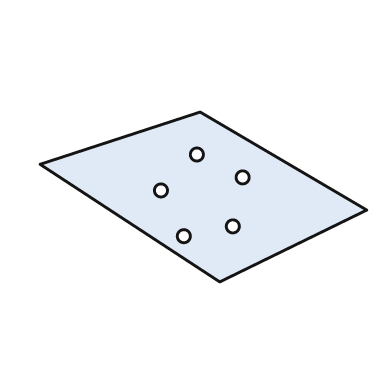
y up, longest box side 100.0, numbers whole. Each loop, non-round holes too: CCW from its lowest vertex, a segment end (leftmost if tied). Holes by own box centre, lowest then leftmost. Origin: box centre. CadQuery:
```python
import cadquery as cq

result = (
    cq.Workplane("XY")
    .moveTo(5.0, -26.0)
    .lineTo(50.0, -4.0)
    .lineTo(-1.0, 26.0)
    .lineTo(-50.0, 10.0)
    .close()
    .moveTo(-6.0, -12.0)
    .circle(2.0)
    .moveTo(9.0, -9.0)
    .circle(2.0)
    .moveTo(-13.0, 2.0)
    .circle(2.0)
    .moveTo(12.0, 6.0)
    .circle(2.0)
    .moveTo(-2.0, 13.0)
    .circle(2.0)
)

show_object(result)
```